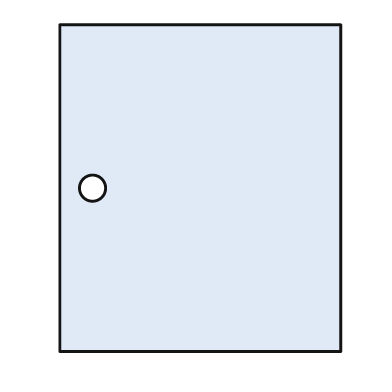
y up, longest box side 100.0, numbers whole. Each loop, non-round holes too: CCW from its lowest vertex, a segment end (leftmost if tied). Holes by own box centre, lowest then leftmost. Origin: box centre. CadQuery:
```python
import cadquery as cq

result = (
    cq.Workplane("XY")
    .moveTo(-43.0, -50.0)
    .lineTo(43.0, -50.0)
    .lineTo(43.0, 50.0)
    .lineTo(-43.0, 50.0)
    .close()
    .moveTo(-33.0, 0.0)
    .circle(4.0)
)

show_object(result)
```